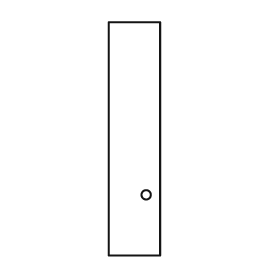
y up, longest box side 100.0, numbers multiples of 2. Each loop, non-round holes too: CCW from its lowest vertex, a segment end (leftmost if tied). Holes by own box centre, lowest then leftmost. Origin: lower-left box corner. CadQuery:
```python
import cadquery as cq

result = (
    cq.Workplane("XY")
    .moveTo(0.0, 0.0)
    .lineTo(22.0, 0.0)
    .lineTo(22.0, 100.0)
    .lineTo(0.0, 100.0)
    .close()
    .moveTo(16.0, 26.0)
    .circle(2.0)
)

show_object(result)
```